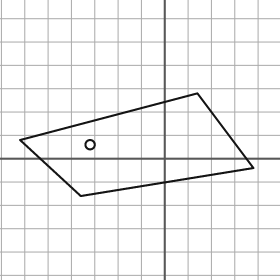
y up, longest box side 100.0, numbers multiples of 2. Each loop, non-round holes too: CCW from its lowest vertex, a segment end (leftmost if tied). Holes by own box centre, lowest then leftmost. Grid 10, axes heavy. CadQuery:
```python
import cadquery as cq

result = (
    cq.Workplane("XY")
    .moveTo(-36.0, -16.0)
    .lineTo(38.0, -4.0)
    .lineTo(14.0, 28.0)
    .lineTo(-62.0, 8.0)
    .close()
    .moveTo(-32.0, 6.0)
    .circle(2.0)
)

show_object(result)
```